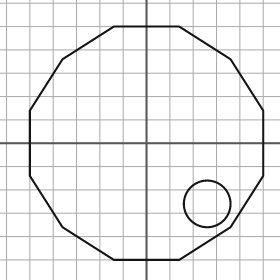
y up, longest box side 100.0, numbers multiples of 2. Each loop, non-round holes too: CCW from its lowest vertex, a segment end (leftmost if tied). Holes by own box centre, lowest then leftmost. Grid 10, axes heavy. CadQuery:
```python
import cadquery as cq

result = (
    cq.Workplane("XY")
    .moveTo(-14.0, -50.0)
    .lineTo(14.0, -50.0)
    .lineTo(36.0, -36.0)
    .lineTo(50.0, -14.0)
    .lineTo(50.0, 14.0)
    .lineTo(36.0, 36.0)
    .lineTo(14.0, 50.0)
    .lineTo(-14.0, 50.0)
    .lineTo(-36.0, 36.0)
    .lineTo(-50.0, 14.0)
    .lineTo(-50.0, -14.0)
    .lineTo(-36.0, -36.0)
    .close()
    .moveTo(26.0, -26.0)
    .circle(10.0)
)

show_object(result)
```